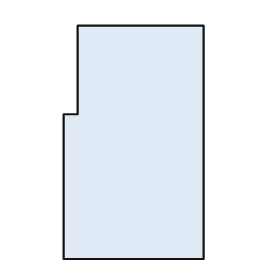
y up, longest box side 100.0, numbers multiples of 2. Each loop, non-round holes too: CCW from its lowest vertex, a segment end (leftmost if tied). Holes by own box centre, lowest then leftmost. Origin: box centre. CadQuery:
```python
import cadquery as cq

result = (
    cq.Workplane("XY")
    .moveTo(-30.0, -50.0)
    .lineTo(30.0, -50.0)
    .lineTo(30.0, 50.0)
    .lineTo(-24.0, 50.0)
    .lineTo(-24.0, 12.0)
    .lineTo(-30.0, 12.0)
    .close()
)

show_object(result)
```